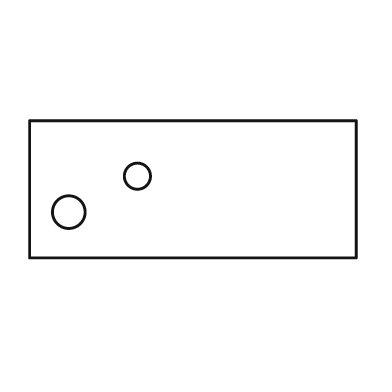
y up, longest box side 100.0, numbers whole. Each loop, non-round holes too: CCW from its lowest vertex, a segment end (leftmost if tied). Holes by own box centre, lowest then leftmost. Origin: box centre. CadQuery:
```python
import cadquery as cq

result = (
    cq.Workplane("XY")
    .moveTo(-50.0, -21.0)
    .lineTo(50.0, -21.0)
    .lineTo(50.0, 21.0)
    .lineTo(-50.0, 21.0)
    .close()
    .moveTo(-38.0, -7.0)
    .circle(5.0)
    .moveTo(-17.0, 4.0)
    .circle(4.0)
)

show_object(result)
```